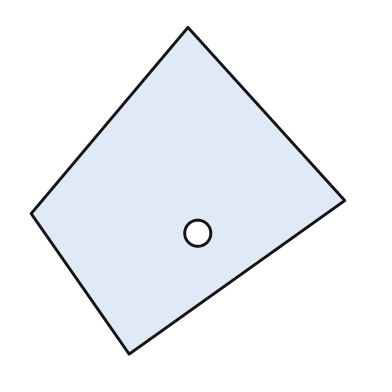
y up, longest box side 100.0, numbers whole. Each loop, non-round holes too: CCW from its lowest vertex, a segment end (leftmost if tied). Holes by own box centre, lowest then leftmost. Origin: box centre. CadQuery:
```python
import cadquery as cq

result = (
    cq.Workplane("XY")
    .moveTo(-18.0, -50.0)
    .lineTo(48.0, -3.0)
    .lineTo(0.0, 50.0)
    .lineTo(-48.0, -7.0)
    .close()
    .moveTo(3.0, -13.0)
    .circle(4.0)
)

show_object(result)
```